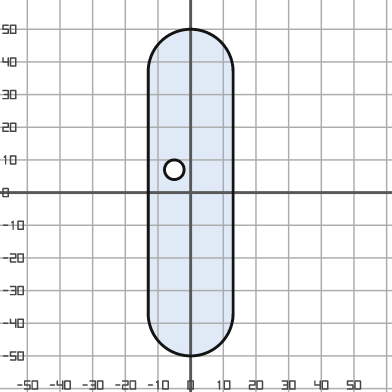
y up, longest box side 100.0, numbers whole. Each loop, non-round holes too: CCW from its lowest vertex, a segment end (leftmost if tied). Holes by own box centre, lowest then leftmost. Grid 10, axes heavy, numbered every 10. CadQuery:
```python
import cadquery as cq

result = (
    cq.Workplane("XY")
    .moveTo(-13.0, -37.0)
    .threePointArc((0.0, -50.0), (13.0, -37.0))
    .lineTo(13.0, 37.0)
    .threePointArc((0.0, 50.0), (-13.0, 37.0))
    .close()
    .moveTo(-5.0, 7.0)
    .circle(3.0)
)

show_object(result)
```